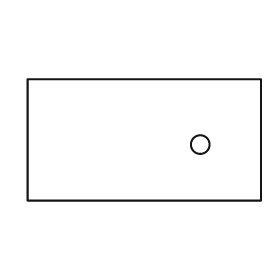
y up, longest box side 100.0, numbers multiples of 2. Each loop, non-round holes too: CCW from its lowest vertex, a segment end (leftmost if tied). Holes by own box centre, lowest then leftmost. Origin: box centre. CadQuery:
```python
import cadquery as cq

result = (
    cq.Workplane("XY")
    .moveTo(-50.0, -26.0)
    .lineTo(50.0, -26.0)
    .lineTo(50.0, 26.0)
    .lineTo(-50.0, 26.0)
    .close()
    .moveTo(24.0, -2.0)
    .circle(4.0)
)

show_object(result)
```